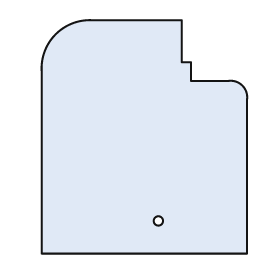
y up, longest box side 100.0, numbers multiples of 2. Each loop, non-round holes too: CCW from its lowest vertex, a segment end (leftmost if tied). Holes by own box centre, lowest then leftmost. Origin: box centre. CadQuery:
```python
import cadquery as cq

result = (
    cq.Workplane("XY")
    .moveTo(-44.0, -50.0)
    .lineTo(44.0, -50.0)
    .lineTo(44.0, 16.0)
    .threePointArc((42.0, 22.0), (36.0, 24.0))
    .lineTo(20.0, 24.0)
    .lineTo(20.0, 32.0)
    .lineTo(16.0, 32.0)
    .lineTo(16.0, 50.0)
    .lineTo(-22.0, 50.0)
    .threePointArc((-38.0, 44.0), (-44.0, 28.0))
    .close()
    .moveTo(6.0, -36.0)
    .circle(2.0)
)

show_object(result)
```